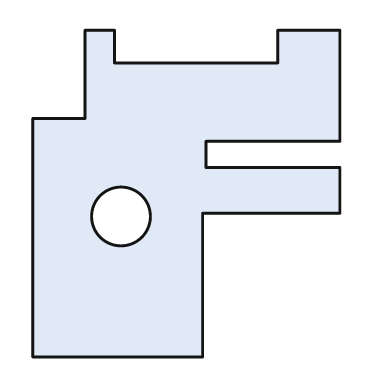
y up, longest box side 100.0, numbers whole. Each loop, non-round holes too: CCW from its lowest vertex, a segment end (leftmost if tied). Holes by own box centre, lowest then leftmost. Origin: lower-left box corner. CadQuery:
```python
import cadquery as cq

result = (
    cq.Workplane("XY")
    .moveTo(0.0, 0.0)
    .lineTo(52.0, 0.0)
    .lineTo(52.0, 44.0)
    .lineTo(94.0, 44.0)
    .lineTo(94.0, 58.0)
    .lineTo(53.0, 58.0)
    .lineTo(53.0, 66.0)
    .lineTo(94.0, 66.0)
    .lineTo(94.0, 100.0)
    .lineTo(75.0, 100.0)
    .lineTo(75.0, 90.0)
    .lineTo(25.0, 90.0)
    .lineTo(25.0, 100.0)
    .lineTo(16.0, 100.0)
    .lineTo(16.0, 73.0)
    .lineTo(0.0, 73.0)
    .close()
    .moveTo(27.0, 43.0)
    .circle(9.0)
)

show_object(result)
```